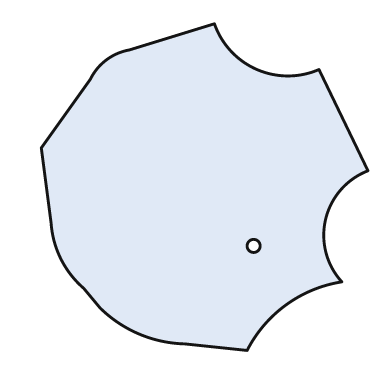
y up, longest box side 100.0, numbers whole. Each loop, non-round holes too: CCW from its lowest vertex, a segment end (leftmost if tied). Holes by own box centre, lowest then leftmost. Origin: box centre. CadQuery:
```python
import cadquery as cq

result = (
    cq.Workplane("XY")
    .moveTo(13.0, -50.0)
    .threePointArc((25.0, -36.0), (42.0, -29.0))
    .threePointArc((37.0, -10.0), (50.0, 5.0))
    .lineTo(35.0, 36.0)
    .threePointArc((16.0, 36.0), (3.0, 50.0))
    .lineTo(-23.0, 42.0)
    .threePointArc((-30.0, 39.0), (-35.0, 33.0))
    .lineTo(-50.0, 12.0)
    .lineTo(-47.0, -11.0)
    .threePointArc((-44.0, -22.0), (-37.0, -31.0))
    .lineTo(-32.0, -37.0)
    .threePointArc((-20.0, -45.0), (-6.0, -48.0))
    .close()
    .moveTo(15.0, -18.0)
    .circle(2.0)
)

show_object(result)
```